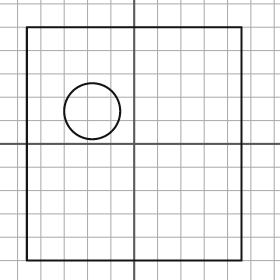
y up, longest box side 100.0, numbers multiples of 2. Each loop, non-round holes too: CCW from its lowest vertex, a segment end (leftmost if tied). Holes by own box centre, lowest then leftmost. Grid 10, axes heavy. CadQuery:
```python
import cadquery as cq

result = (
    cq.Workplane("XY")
    .moveTo(-46.0, -50.0)
    .lineTo(46.0, -50.0)
    .lineTo(46.0, 50.0)
    .lineTo(-46.0, 50.0)
    .close()
    .moveTo(-18.0, 14.0)
    .circle(12.0)
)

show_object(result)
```